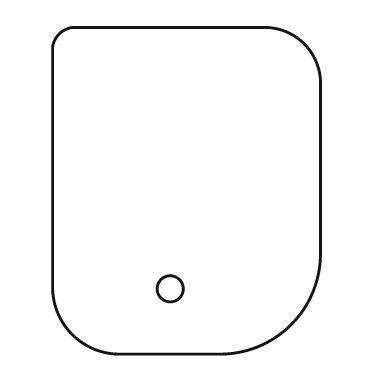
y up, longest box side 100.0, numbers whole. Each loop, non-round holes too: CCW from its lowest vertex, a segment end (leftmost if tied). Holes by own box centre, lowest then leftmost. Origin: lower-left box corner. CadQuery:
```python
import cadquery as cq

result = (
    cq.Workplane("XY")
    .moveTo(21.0, 0.0)
    .lineTo(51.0, 0.0)
    .threePointArc((73.0, 9.0), (82.0, 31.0))
    .lineTo(82.0, 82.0)
    .threePointArc((77.0, 95.0), (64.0, 100.0))
    .lineTo(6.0, 100.0)
    .threePointArc((2.0, 98.0), (0.0, 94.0))
    .lineTo(0.0, 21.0)
    .threePointArc((6.0, 6.0), (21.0, 0.0))
    .close()
    .moveTo(36.0, 20.0)
    .circle(4.0)
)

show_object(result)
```